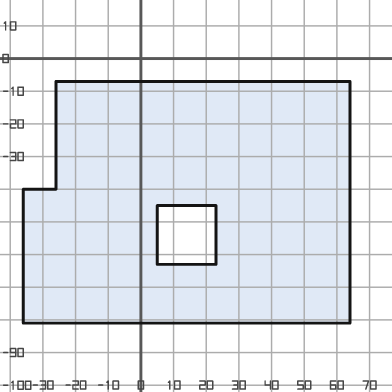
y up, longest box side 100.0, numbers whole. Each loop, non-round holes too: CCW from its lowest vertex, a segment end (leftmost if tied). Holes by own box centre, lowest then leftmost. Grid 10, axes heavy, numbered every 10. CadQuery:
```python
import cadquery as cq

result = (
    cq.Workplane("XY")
    .moveTo(-36.0, -81.0)
    .lineTo(64.0, -81.0)
    .lineTo(64.0, -7.0)
    .lineTo(-26.0, -7.0)
    .lineTo(-26.0, -40.0)
    .lineTo(-36.0, -40.0)
    .close()
    .moveTo(5.0, -63.0)
    .lineTo(23.0, -63.0)
    .lineTo(23.0, -45.0)
    .lineTo(5.0, -45.0)
    .close()
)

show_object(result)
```